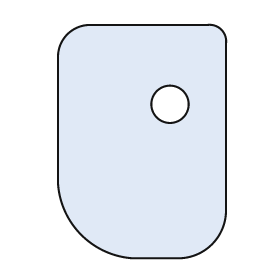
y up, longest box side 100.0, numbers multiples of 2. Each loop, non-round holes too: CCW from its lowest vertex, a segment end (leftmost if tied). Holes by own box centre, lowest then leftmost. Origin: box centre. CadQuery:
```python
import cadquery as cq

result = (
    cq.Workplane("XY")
    .moveTo(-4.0, -50.0)
    .lineTo(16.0, -50.0)
    .threePointArc((30.0, -44.0), (36.0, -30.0))
    .lineTo(36.0, 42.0)
    .threePointArc((34.0, 48.0), (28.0, 50.0))
    .lineTo(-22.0, 50.0)
    .threePointArc((-32.0, 46.0), (-36.0, 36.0))
    .lineTo(-36.0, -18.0)
    .threePointArc((-26.0, -40.0), (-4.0, -50.0))
    .close()
    .moveTo(12.0, 16.0)
    .circle(8.0)
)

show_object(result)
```